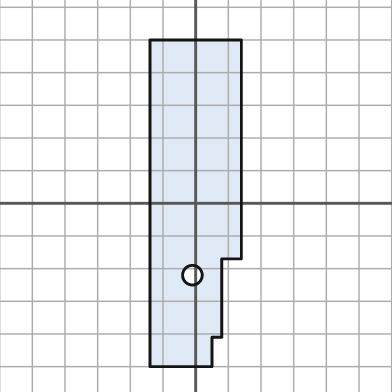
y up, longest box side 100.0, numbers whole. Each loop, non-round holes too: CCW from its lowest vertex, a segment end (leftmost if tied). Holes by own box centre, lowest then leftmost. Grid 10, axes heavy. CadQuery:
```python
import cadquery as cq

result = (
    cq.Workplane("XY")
    .moveTo(-14.0, -50.0)
    .lineTo(5.0, -50.0)
    .lineTo(5.0, -41.0)
    .lineTo(8.0, -41.0)
    .lineTo(8.0, -17.0)
    .lineTo(14.0, -17.0)
    .lineTo(14.0, 50.0)
    .lineTo(-14.0, 50.0)
    .close()
    .moveTo(-1.0, -22.0)
    .circle(3.0)
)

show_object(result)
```